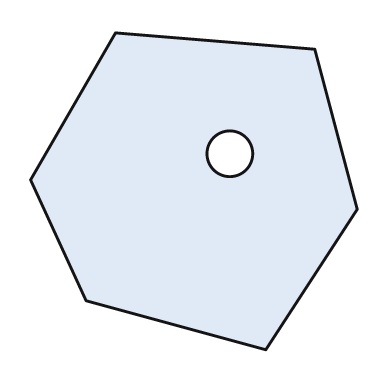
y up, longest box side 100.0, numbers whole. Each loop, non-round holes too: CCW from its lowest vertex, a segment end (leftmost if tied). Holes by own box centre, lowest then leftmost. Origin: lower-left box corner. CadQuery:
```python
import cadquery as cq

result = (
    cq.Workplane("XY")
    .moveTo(72.0, 0.0)
    .lineTo(100.0, 43.0)
    .lineTo(87.0, 92.0)
    .lineTo(26.0, 97.0)
    .lineTo(0.0, 52.0)
    .lineTo(17.0, 15.0)
    .close()
    .moveTo(61.0, 60.0)
    .circle(7.0)
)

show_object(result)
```